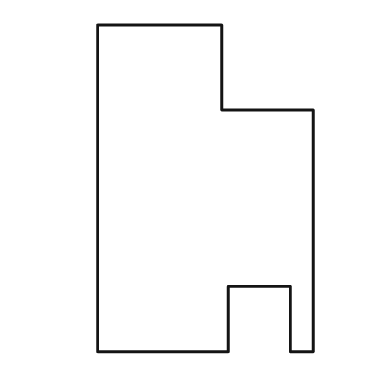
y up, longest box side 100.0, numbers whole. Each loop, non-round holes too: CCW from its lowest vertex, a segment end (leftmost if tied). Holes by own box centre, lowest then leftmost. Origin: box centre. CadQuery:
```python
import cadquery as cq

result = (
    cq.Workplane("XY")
    .moveTo(-33.0, -50.0)
    .lineTo(7.0, -50.0)
    .lineTo(7.0, -30.0)
    .lineTo(26.0, -30.0)
    .lineTo(26.0, -50.0)
    .lineTo(33.0, -50.0)
    .lineTo(33.0, 24.0)
    .lineTo(5.0, 24.0)
    .lineTo(5.0, 50.0)
    .lineTo(-33.0, 50.0)
    .close()
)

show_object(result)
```